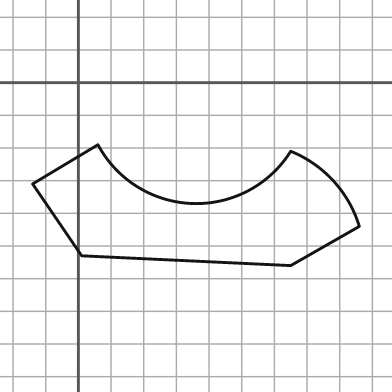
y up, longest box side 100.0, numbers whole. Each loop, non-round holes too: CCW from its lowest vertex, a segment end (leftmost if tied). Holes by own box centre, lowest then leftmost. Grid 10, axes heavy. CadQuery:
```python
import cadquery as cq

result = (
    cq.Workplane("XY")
    .moveTo(65.0, -56.0)
    .lineTo(86.0, -44.0)
    .threePointArc((78.0, -30.0), (65.0, -21.0))
    .threePointArc((35.0, -37.0), (6.0, -19.0))
    .lineTo(-14.0, -31.0)
    .lineTo(1.0, -53.0)
    .close()
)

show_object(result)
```